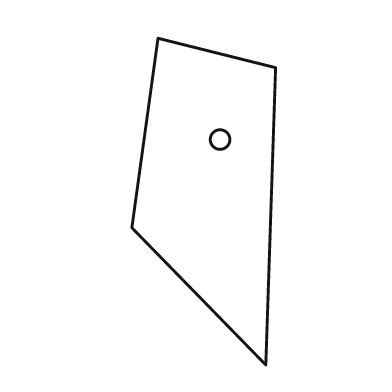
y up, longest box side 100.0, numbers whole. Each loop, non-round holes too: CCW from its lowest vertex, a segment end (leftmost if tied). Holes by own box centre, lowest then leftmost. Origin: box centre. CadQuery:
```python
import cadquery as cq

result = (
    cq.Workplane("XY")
    .moveTo(19.0, -50.0)
    .lineTo(22.0, 41.0)
    .lineTo(-14.0, 50.0)
    .lineTo(-22.0, -8.0)
    .close()
    .moveTo(5.0, 19.0)
    .circle(3.0)
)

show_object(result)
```